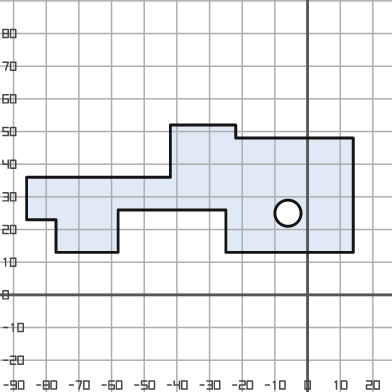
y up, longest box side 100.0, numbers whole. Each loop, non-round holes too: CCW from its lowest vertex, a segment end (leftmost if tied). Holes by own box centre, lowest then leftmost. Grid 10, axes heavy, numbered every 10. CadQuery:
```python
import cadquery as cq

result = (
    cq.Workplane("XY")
    .moveTo(-77.0, 13.0)
    .lineTo(-58.0, 13.0)
    .lineTo(-58.0, 26.0)
    .lineTo(-25.0, 26.0)
    .lineTo(-25.0, 13.0)
    .lineTo(14.0, 13.0)
    .lineTo(14.0, 48.0)
    .lineTo(-22.0, 48.0)
    .lineTo(-22.0, 52.0)
    .lineTo(-42.0, 52.0)
    .lineTo(-42.0, 36.0)
    .lineTo(-86.0, 36.0)
    .lineTo(-86.0, 23.0)
    .lineTo(-77.0, 23.0)
    .close()
    .moveTo(-6.0, 25.0)
    .circle(4.0)
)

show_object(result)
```